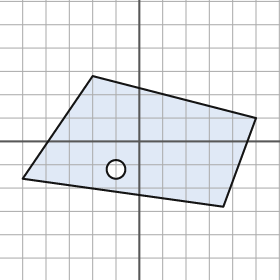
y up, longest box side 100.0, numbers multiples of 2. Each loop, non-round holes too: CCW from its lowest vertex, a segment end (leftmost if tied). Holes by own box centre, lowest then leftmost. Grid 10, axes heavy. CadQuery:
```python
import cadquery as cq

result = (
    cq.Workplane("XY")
    .moveTo(36.0, -28.0)
    .lineTo(50.0, 10.0)
    .lineTo(-20.0, 28.0)
    .lineTo(-50.0, -16.0)
    .close()
    .moveTo(-10.0, -12.0)
    .circle(4.0)
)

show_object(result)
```